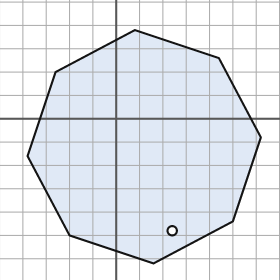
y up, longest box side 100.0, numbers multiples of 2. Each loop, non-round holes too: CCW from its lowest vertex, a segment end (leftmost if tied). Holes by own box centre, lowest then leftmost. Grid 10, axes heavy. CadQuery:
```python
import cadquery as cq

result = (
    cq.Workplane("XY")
    .moveTo(16.0, -62.0)
    .lineTo(50.0, -44.0)
    .lineTo(62.0, -8.0)
    .lineTo(44.0, 26.0)
    .lineTo(8.0, 38.0)
    .lineTo(-26.0, 20.0)
    .lineTo(-38.0, -16.0)
    .lineTo(-20.0, -50.0)
    .close()
    .moveTo(24.0, -48.0)
    .circle(2.0)
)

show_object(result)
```